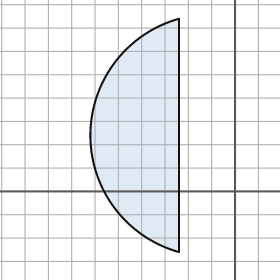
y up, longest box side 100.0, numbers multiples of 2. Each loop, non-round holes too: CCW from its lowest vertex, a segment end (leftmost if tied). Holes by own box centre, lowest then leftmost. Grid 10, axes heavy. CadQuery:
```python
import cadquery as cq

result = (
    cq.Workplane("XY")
    .moveTo(-24.0, -26.0)
    .lineTo(-24.0, 74.0)
    .threePointArc((-62.0, 24.0), (-24.0, -26.0))
    .close()
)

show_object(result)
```